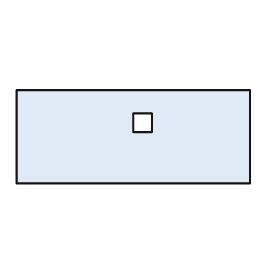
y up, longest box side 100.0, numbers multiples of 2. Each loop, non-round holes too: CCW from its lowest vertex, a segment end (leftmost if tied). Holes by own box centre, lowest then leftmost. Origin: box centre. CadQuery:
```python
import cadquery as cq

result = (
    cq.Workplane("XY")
    .moveTo(-50.0, -20.0)
    .lineTo(50.0, -20.0)
    .lineTo(50.0, 20.0)
    .lineTo(-50.0, 20.0)
    .close()
    .moveTo(0.0, 2.0)
    .lineTo(8.0, 2.0)
    .lineTo(8.0, 10.0)
    .lineTo(0.0, 10.0)
    .close()
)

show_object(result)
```